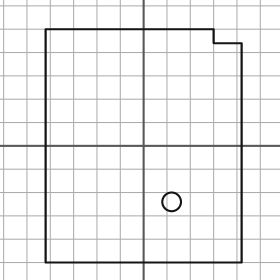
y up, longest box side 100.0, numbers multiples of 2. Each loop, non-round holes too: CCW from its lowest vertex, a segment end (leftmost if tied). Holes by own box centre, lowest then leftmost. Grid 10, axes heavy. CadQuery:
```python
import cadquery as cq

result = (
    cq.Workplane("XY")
    .moveTo(-42.0, -50.0)
    .lineTo(42.0, -50.0)
    .lineTo(42.0, 44.0)
    .lineTo(30.0, 44.0)
    .lineTo(30.0, 50.0)
    .lineTo(-42.0, 50.0)
    .close()
    .moveTo(12.0, -24.0)
    .circle(4.0)
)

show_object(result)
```